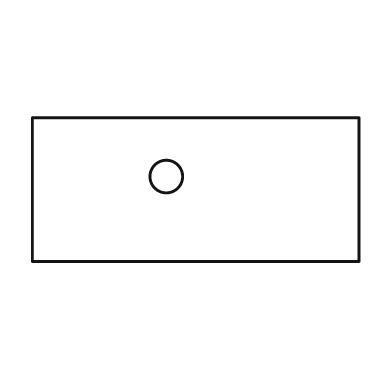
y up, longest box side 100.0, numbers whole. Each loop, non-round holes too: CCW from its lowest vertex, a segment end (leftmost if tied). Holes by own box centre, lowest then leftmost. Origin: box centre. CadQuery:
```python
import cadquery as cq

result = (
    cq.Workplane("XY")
    .moveTo(-50.0, -22.0)
    .lineTo(50.0, -22.0)
    .lineTo(50.0, 22.0)
    .lineTo(-50.0, 22.0)
    .close()
    .moveTo(-9.0, 4.0)
    .circle(5.0)
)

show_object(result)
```